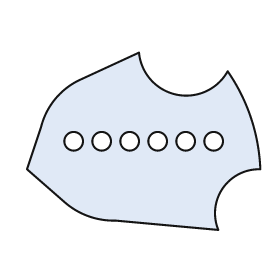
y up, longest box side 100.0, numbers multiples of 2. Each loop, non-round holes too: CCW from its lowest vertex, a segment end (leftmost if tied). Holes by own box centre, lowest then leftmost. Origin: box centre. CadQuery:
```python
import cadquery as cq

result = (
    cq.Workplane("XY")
    .moveTo(32.0, -38.0)
    .threePointArc((34.0, -20.0), (50.0, -12.0))
    .threePointArc((46.0, 10.0), (36.0, 30.0))
    .threePointArc((14.0, 20.0), (-2.0, 38.0))
    .lineTo(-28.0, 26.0)
    .threePointArc((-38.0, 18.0), (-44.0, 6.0))
    .lineTo(-50.0, -12.0)
    .lineTo(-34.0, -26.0)
    .threePointArc((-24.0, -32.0), (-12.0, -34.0))
    .close()
    .moveTo(-30.0, 0.0)
    .circle(4.0)
    .moveTo(-18.0, 0.0)
    .circle(4.0)
    .moveTo(-6.0, 0.0)
    .circle(4.0)
    .moveTo(6.0, 0.0)
    .circle(4.0)
    .moveTo(18.0, 0.0)
    .circle(4.0)
    .moveTo(30.0, 0.0)
    .circle(4.0)
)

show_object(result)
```